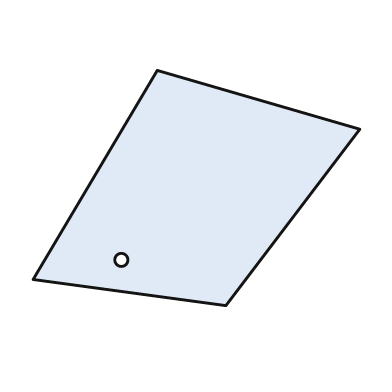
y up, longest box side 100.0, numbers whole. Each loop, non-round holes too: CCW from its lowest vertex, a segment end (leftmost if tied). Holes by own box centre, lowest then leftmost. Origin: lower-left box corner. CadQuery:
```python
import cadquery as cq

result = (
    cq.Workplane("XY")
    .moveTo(59.0, 0.0)
    .lineTo(100.0, 54.0)
    .lineTo(38.0, 72.0)
    .lineTo(0.0, 8.0)
    .close()
    .moveTo(27.0, 14.0)
    .circle(2.0)
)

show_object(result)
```